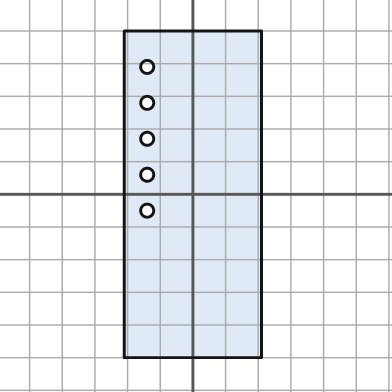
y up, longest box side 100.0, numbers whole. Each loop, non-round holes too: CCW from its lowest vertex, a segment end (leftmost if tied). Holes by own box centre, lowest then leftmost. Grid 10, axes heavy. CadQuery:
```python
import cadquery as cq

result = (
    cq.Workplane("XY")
    .moveTo(-21.0, -50.0)
    .lineTo(21.0, -50.0)
    .lineTo(21.0, 50.0)
    .lineTo(-21.0, 50.0)
    .close()
    .moveTo(-14.0, -5.0)
    .circle(2.0)
    .moveTo(-14.0, 6.0)
    .circle(2.0)
    .moveTo(-14.0, 17.0)
    .circle(2.0)
    .moveTo(-14.0, 28.0)
    .circle(2.0)
    .moveTo(-14.0, 39.0)
    .circle(2.0)
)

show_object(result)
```